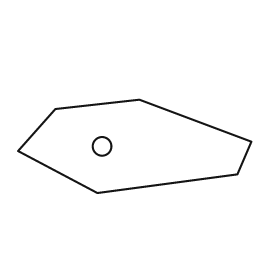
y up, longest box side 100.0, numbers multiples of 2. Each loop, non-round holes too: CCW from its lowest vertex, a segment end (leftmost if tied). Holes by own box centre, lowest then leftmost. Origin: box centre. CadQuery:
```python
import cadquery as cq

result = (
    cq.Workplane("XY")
    .moveTo(-16.0, -20.0)
    .lineTo(44.0, -12.0)
    .lineTo(50.0, 2.0)
    .lineTo(2.0, 20.0)
    .lineTo(-34.0, 16.0)
    .lineTo(-50.0, -2.0)
    .close()
    .moveTo(-14.0, 0.0)
    .circle(4.0)
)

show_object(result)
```